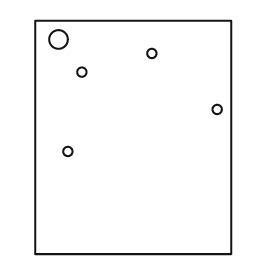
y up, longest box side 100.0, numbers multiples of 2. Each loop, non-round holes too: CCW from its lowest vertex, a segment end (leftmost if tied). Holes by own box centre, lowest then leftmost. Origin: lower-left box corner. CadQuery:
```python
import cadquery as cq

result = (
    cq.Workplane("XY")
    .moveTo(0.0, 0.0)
    .lineTo(84.0, 0.0)
    .lineTo(84.0, 100.0)
    .lineTo(0.0, 100.0)
    .close()
    .moveTo(14.0, 44.0)
    .circle(2.0)
    .moveTo(78.0, 62.0)
    .circle(2.0)
    .moveTo(20.0, 78.0)
    .circle(2.0)
    .moveTo(50.0, 86.0)
    .circle(2.0)
    .moveTo(10.0, 92.0)
    .circle(4.0)
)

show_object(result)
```